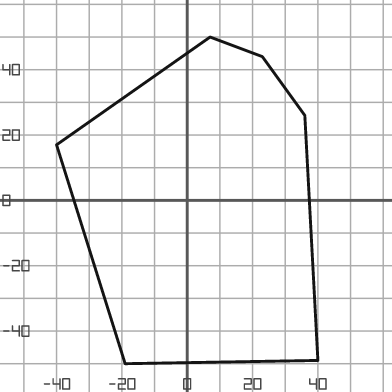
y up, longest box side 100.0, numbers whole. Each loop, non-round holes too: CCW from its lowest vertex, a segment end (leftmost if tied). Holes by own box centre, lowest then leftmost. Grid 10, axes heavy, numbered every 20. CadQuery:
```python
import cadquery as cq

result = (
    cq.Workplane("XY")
    .moveTo(-19.0, -50.0)
    .lineTo(40.0, -49.0)
    .lineTo(36.0, 26.0)
    .lineTo(23.0, 44.0)
    .lineTo(7.0, 50.0)
    .lineTo(-40.0, 17.0)
    .close()
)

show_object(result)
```